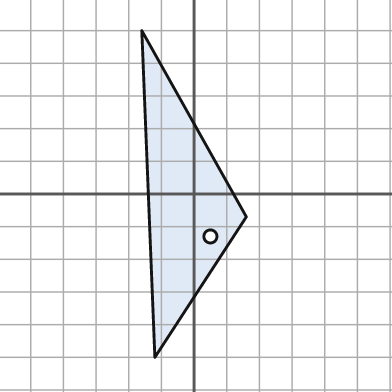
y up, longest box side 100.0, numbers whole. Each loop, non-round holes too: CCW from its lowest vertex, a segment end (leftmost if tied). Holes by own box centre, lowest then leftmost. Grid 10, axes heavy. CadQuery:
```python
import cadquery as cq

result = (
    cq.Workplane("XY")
    .moveTo(-12.0, -50.0)
    .lineTo(16.0, -7.0)
    .lineTo(-16.0, 50.0)
    .close()
    .moveTo(5.0, -13.0)
    .circle(2.0)
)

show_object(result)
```